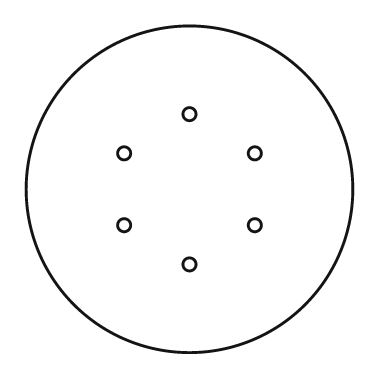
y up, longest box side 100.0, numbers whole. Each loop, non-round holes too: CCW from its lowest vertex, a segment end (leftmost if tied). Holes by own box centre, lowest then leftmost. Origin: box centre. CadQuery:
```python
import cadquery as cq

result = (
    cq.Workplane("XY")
    .moveTo(0.0, 0.0)
    .circle(50.0)
    .moveTo(0.0, -23.0)
    .circle(2.0)
    .moveTo(-20.0, -11.0)
    .circle(2.0)
    .moveTo(20.0, -11.0)
    .circle(2.0)
    .moveTo(-20.0, 11.0)
    .circle(2.0)
    .moveTo(20.0, 11.0)
    .circle(2.0)
    .moveTo(0.0, 23.0)
    .circle(2.0)
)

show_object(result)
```